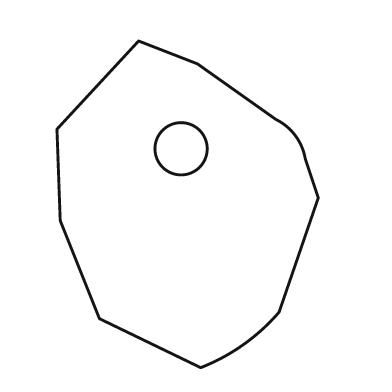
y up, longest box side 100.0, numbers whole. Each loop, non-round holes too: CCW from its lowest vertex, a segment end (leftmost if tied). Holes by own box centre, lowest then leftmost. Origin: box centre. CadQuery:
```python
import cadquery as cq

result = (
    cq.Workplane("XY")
    .moveTo(4.0, -50.0)
    .threePointArc((17.0, -43.0), (28.0, -33.0))
    .lineTo(40.0, 2.0)
    .lineTo(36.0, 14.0)
    .threePointArc((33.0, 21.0), (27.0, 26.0))
    .lineTo(3.0, 43.0)
    .lineTo(-15.0, 50.0)
    .lineTo(-40.0, 23.0)
    .lineTo(-39.0, -5.0)
    .lineTo(-27.0, -35.0)
    .close()
    .moveTo(-2.0, 17.0)
    .circle(8.0)
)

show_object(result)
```